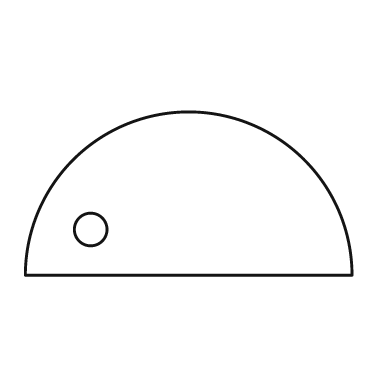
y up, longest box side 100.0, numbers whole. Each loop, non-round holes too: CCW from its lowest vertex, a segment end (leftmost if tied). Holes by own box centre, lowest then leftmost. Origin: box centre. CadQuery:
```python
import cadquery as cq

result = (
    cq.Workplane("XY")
    .moveTo(-50.0, -25.0)
    .lineTo(50.0, -25.0)
    .threePointArc((0.0, 25.0), (-50.0, -25.0))
    .close()
    .moveTo(-30.0, -11.0)
    .circle(5.0)
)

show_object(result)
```